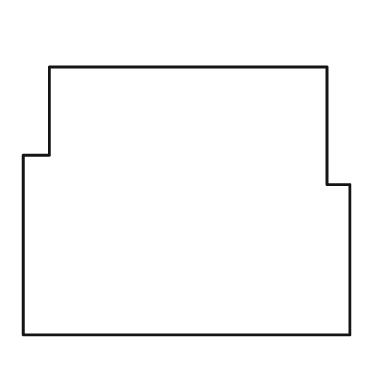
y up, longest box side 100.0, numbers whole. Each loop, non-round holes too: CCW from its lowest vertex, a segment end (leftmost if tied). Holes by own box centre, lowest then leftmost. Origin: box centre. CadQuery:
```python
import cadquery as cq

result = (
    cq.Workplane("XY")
    .moveTo(-50.0, -41.0)
    .lineTo(50.0, -41.0)
    .lineTo(50.0, 5.0)
    .lineTo(43.0, 5.0)
    .lineTo(43.0, 41.0)
    .lineTo(-42.0, 41.0)
    .lineTo(-42.0, 14.0)
    .lineTo(-50.0, 14.0)
    .close()
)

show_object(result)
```